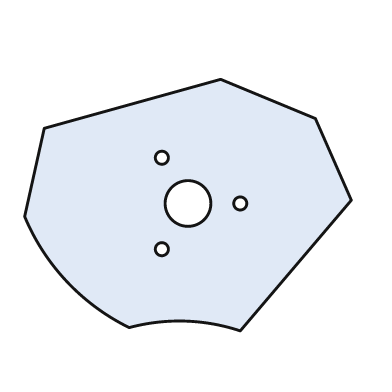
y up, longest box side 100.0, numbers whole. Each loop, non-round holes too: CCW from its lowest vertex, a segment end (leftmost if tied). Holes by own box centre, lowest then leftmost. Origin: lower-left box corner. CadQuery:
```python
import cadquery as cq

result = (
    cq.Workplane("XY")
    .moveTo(66.0, 0.0)
    .lineTo(100.0, 40.0)
    .lineTo(89.0, 65.0)
    .lineTo(60.0, 77.0)
    .lineTo(6.0, 62.0)
    .lineTo(0.0, 35.0)
    .threePointArc((13.0, 15.0), (32.0, 1.0))
    .threePointArc((49.0, 3.0), (66.0, 0.0))
    .close()
    .moveTo(42.0, 25.0)
    .circle(2.0)
    .moveTo(50.0, 39.0)
    .circle(7.0)
    .moveTo(66.0, 39.0)
    .circle(2.0)
    .moveTo(42.0, 53.0)
    .circle(2.0)
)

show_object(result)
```